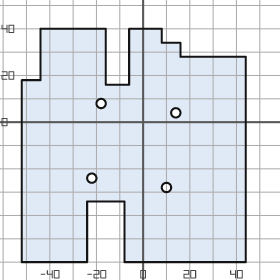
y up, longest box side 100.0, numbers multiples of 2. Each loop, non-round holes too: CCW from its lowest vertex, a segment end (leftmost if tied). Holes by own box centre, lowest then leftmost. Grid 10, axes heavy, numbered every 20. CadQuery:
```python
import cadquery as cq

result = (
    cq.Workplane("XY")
    .moveTo(-52.0, -60.0)
    .lineTo(-24.0, -60.0)
    .lineTo(-24.0, -34.0)
    .lineTo(-8.0, -34.0)
    .lineTo(-8.0, -60.0)
    .lineTo(44.0, -60.0)
    .lineTo(44.0, 28.0)
    .lineTo(16.0, 28.0)
    .lineTo(16.0, 34.0)
    .lineTo(8.0, 34.0)
    .lineTo(8.0, 40.0)
    .lineTo(-6.0, 40.0)
    .lineTo(-6.0, 16.0)
    .lineTo(-16.0, 16.0)
    .lineTo(-16.0, 40.0)
    .lineTo(-44.0, 40.0)
    .lineTo(-44.0, 18.0)
    .lineTo(-52.0, 18.0)
    .close()
    .moveTo(10.0, -28.0)
    .circle(2.0)
    .moveTo(-22.0, -24.0)
    .circle(2.0)
    .moveTo(14.0, 4.0)
    .circle(2.0)
    .moveTo(-18.0, 8.0)
    .circle(2.0)
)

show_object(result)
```